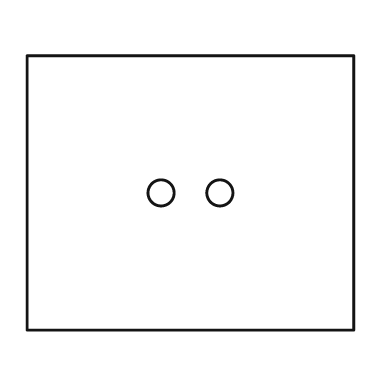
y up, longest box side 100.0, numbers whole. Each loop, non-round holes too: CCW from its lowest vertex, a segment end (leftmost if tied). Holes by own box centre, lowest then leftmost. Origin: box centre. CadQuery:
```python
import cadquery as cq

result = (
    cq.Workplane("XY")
    .moveTo(-50.0, -42.0)
    .lineTo(50.0, -42.0)
    .lineTo(50.0, 42.0)
    .lineTo(-50.0, 42.0)
    .close()
    .moveTo(-9.0, 0.0)
    .circle(4.0)
    .moveTo(9.0, 0.0)
    .circle(4.0)
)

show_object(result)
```